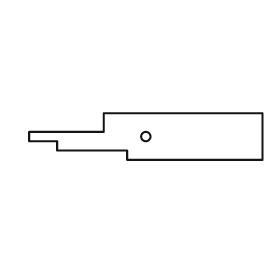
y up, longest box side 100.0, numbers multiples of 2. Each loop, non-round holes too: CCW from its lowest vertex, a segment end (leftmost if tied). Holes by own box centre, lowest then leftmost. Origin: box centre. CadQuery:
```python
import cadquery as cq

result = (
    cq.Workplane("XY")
    .moveTo(-8.0, -10.0)
    .lineTo(50.0, -10.0)
    .lineTo(50.0, 10.0)
    .lineTo(-18.0, 10.0)
    .lineTo(-18.0, 2.0)
    .lineTo(-50.0, 2.0)
    .lineTo(-50.0, -2.0)
    .lineTo(-38.0, -2.0)
    .lineTo(-38.0, -6.0)
    .lineTo(-8.0, -6.0)
    .close()
    .moveTo(0.0, 0.0)
    .circle(2.0)
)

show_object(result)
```